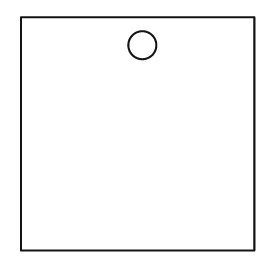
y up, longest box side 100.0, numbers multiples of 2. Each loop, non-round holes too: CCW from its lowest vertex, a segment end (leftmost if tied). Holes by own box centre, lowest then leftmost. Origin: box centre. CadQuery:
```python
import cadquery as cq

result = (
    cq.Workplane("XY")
    .moveTo(-50.0, -50.0)
    .lineTo(50.0, -50.0)
    .lineTo(50.0, 50.0)
    .lineTo(-50.0, 50.0)
    .close()
    .moveTo(2.0, 38.0)
    .circle(6.0)
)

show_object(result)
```